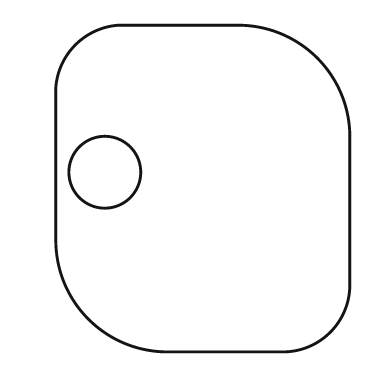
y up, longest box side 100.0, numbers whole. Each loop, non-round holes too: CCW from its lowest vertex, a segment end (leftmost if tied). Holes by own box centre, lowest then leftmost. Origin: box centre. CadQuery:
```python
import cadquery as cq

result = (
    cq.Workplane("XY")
    .moveTo(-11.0, -50.0)
    .lineTo(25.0, -50.0)
    .threePointArc((39.0, -44.0), (45.0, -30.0))
    .lineTo(45.0, 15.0)
    .threePointArc((35.0, 40.0), (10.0, 50.0))
    .lineTo(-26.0, 50.0)
    .threePointArc((-39.0, 44.0), (-45.0, 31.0))
    .lineTo(-45.0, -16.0)
    .threePointArc((-35.0, -40.0), (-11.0, -50.0))
    .close()
    .moveTo(-30.0, 5.0)
    .circle(11.0)
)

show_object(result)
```